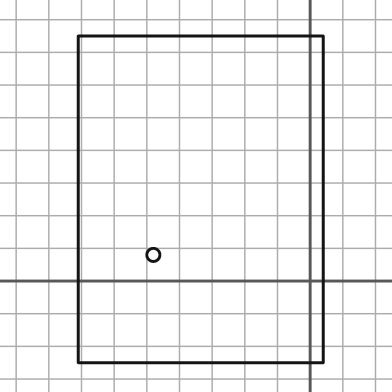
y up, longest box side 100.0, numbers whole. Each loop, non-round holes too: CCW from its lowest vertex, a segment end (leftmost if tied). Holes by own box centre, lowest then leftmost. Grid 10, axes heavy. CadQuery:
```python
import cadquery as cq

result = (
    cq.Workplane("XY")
    .moveTo(-71.0, -25.0)
    .lineTo(4.0, -25.0)
    .lineTo(4.0, 75.0)
    .lineTo(-71.0, 75.0)
    .close()
    .moveTo(-48.0, 8.0)
    .circle(2.0)
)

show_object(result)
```